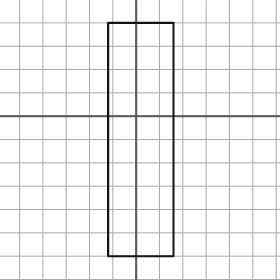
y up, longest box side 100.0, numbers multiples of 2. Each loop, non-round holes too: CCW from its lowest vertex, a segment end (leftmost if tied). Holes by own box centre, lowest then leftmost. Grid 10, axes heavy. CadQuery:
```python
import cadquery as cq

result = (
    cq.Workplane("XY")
    .moveTo(-12.0, -60.0)
    .lineTo(16.0, -60.0)
    .lineTo(16.0, 40.0)
    .lineTo(-12.0, 40.0)
    .close()
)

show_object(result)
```